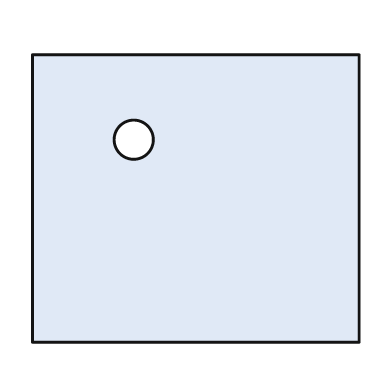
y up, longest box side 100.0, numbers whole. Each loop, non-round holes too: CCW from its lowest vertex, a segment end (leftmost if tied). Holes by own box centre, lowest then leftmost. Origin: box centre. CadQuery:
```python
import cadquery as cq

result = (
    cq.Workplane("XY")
    .moveTo(-50.0, -44.0)
    .lineTo(50.0, -44.0)
    .lineTo(50.0, 44.0)
    .lineTo(-50.0, 44.0)
    .close()
    .moveTo(-19.0, 18.0)
    .circle(6.0)
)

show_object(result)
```